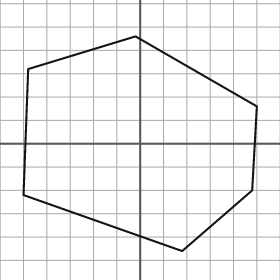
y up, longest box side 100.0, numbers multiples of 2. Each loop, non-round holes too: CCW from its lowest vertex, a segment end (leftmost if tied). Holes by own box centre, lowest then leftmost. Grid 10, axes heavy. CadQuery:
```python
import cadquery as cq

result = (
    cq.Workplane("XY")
    .moveTo(18.0, -46.0)
    .lineTo(48.0, -20.0)
    .lineTo(50.0, 16.0)
    .lineTo(-2.0, 46.0)
    .lineTo(-48.0, 32.0)
    .lineTo(-50.0, -22.0)
    .close()
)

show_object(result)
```